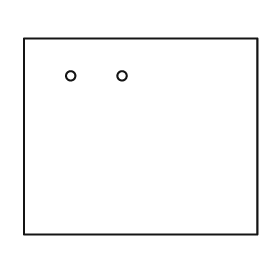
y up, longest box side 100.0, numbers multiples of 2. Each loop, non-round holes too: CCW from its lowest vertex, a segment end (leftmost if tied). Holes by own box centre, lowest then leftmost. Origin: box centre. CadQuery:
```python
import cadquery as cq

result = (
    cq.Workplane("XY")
    .moveTo(-50.0, -42.0)
    .lineTo(50.0, -42.0)
    .lineTo(50.0, 42.0)
    .lineTo(-50.0, 42.0)
    .close()
    .moveTo(-30.0, 26.0)
    .circle(2.0)
    .moveTo(-8.0, 26.0)
    .circle(2.0)
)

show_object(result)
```